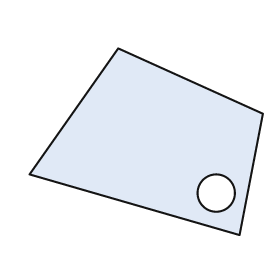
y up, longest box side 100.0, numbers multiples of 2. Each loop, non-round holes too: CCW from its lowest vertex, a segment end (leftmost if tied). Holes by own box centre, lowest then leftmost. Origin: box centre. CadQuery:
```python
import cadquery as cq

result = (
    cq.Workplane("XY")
    .moveTo(40.0, -40.0)
    .lineTo(50.0, 12.0)
    .lineTo(-12.0, 40.0)
    .lineTo(-50.0, -14.0)
    .close()
    .moveTo(30.0, -22.0)
    .circle(8.0)
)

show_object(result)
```